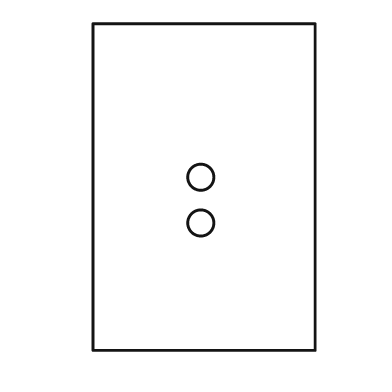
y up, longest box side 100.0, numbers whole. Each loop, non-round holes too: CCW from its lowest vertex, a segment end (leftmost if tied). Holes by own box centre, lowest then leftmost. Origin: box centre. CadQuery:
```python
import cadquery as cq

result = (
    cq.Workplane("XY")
    .moveTo(-34.0, -50.0)
    .lineTo(34.0, -50.0)
    .lineTo(34.0, 50.0)
    .lineTo(-34.0, 50.0)
    .close()
    .moveTo(-1.0, -11.0)
    .circle(4.0)
    .moveTo(-1.0, 3.0)
    .circle(4.0)
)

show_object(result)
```